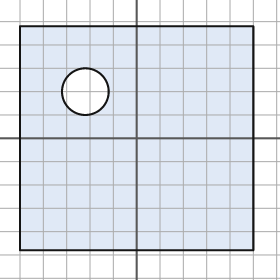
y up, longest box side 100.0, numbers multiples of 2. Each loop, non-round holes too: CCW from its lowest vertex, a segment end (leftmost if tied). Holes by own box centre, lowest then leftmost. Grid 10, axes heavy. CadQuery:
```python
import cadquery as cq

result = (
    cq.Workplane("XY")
    .moveTo(-50.0, -48.0)
    .lineTo(50.0, -48.0)
    .lineTo(50.0, 48.0)
    .lineTo(-50.0, 48.0)
    .close()
    .moveTo(-22.0, 20.0)
    .circle(10.0)
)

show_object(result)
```